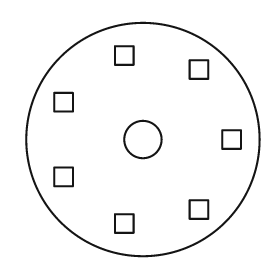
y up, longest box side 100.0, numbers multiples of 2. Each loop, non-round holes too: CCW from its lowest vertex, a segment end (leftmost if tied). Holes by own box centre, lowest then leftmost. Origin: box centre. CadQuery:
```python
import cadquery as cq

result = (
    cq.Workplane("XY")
    .moveTo(0.0, 0.0)
    .circle(50.0)
    .moveTo(-12.0, -40.0)
    .lineTo(-4.0, -40.0)
    .lineTo(-4.0, -32.0)
    .lineTo(-12.0, -32.0)
    .close()
    .moveTo(20.0, -34.0)
    .lineTo(28.0, -34.0)
    .lineTo(28.0, -26.0)
    .lineTo(20.0, -26.0)
    .close()
    .moveTo(-38.0, -20.0)
    .lineTo(-30.0, -20.0)
    .lineTo(-30.0, -12.0)
    .lineTo(-38.0, -12.0)
    .close()
    .moveTo(0.0, 0.0)
    .circle(8.0)
    .moveTo(34.0, -4.0)
    .lineTo(42.0, -4.0)
    .lineTo(42.0, 4.0)
    .lineTo(34.0, 4.0)
    .close()
    .moveTo(-38.0, 12.0)
    .lineTo(-30.0, 12.0)
    .lineTo(-30.0, 20.0)
    .lineTo(-38.0, 20.0)
    .close()
    .moveTo(20.0, 26.0)
    .lineTo(28.0, 26.0)
    .lineTo(28.0, 34.0)
    .lineTo(20.0, 34.0)
    .close()
    .moveTo(-12.0, 32.0)
    .lineTo(-4.0, 32.0)
    .lineTo(-4.0, 40.0)
    .lineTo(-12.0, 40.0)
    .close()
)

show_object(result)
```